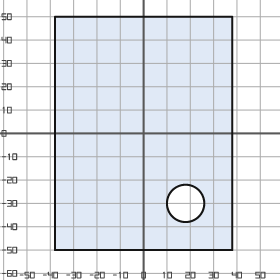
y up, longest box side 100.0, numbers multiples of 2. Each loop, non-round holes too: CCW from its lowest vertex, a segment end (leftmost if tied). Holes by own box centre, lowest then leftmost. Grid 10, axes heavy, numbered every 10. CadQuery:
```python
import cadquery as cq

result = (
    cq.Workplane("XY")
    .moveTo(-38.0, -50.0)
    .lineTo(38.0, -50.0)
    .lineTo(38.0, 50.0)
    .lineTo(-38.0, 50.0)
    .close()
    .moveTo(18.0, -30.0)
    .circle(8.0)
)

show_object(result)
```